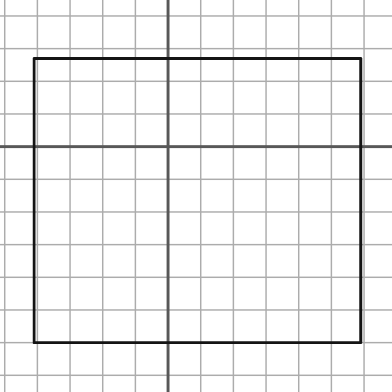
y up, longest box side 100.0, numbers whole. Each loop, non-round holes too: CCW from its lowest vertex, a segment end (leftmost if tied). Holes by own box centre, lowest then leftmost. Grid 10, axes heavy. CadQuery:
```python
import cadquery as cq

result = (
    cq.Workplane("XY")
    .moveTo(-41.0, -60.0)
    .lineTo(59.0, -60.0)
    .lineTo(59.0, 27.0)
    .lineTo(-41.0, 27.0)
    .close()
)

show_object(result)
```